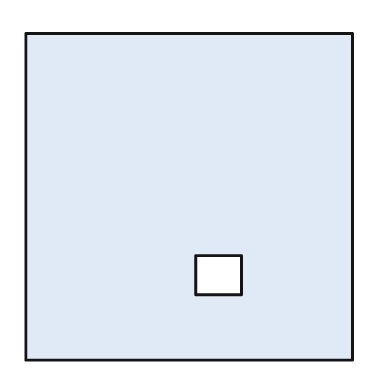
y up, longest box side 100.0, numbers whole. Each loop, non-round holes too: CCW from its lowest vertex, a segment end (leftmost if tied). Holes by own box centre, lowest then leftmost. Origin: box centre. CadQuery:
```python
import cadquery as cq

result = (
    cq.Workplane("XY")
    .moveTo(-50.0, -50.0)
    .lineTo(50.0, -50.0)
    .lineTo(50.0, 50.0)
    .lineTo(-50.0, 50.0)
    .close()
    .moveTo(2.0, -30.0)
    .lineTo(16.0, -30.0)
    .lineTo(16.0, -18.0)
    .lineTo(2.0, -18.0)
    .close()
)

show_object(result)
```